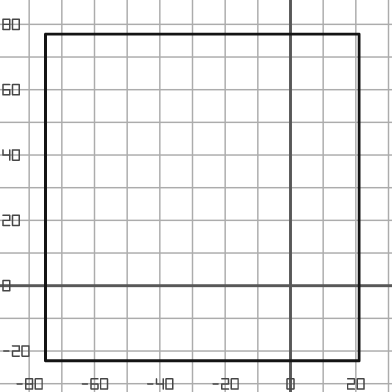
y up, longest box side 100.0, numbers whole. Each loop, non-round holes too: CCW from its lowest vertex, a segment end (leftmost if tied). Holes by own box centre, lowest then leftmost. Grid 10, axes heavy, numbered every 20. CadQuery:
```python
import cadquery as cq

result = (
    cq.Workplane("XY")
    .moveTo(-75.0, -23.0)
    .lineTo(21.0, -23.0)
    .lineTo(21.0, 77.0)
    .lineTo(-75.0, 77.0)
    .close()
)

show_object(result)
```